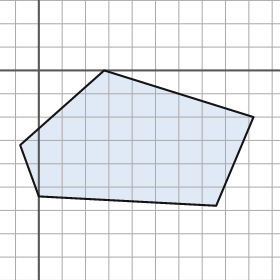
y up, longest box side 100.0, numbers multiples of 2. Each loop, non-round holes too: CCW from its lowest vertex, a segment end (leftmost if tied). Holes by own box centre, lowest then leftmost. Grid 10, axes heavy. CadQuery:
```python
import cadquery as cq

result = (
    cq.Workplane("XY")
    .moveTo(76.0, -58.0)
    .lineTo(92.0, -20.0)
    .lineTo(28.0, 0.0)
    .lineTo(-8.0, -32.0)
    .lineTo(0.0, -54.0)
    .close()
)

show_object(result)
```